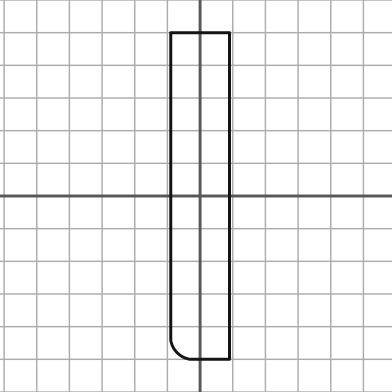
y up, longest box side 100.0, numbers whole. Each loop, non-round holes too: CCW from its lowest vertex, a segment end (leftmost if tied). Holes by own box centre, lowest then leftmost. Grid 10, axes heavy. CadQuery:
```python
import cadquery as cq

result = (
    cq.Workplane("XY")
    .moveTo(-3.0, -50.0)
    .lineTo(9.0, -50.0)
    .lineTo(9.0, 50.0)
    .lineTo(-9.0, 50.0)
    .lineTo(-9.0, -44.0)
    .threePointArc((-7.0, -48.0), (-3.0, -50.0))
    .close()
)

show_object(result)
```